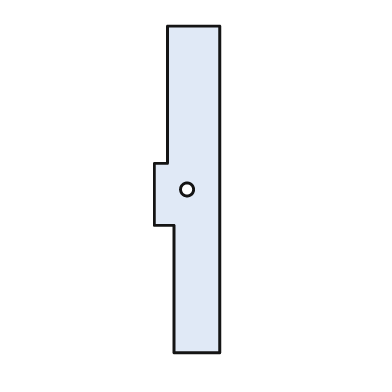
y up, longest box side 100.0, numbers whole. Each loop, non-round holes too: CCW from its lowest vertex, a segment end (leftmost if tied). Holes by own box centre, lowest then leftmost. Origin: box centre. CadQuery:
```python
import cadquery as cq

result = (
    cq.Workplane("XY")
    .moveTo(-4.0, -50.0)
    .lineTo(10.0, -50.0)
    .lineTo(10.0, 50.0)
    .lineTo(-6.0, 50.0)
    .lineTo(-6.0, 8.0)
    .lineTo(-10.0, 8.0)
    .lineTo(-10.0, -11.0)
    .lineTo(-4.0, -11.0)
    .close()
    .moveTo(0.0, 0.0)
    .circle(2.0)
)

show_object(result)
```